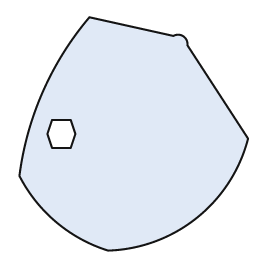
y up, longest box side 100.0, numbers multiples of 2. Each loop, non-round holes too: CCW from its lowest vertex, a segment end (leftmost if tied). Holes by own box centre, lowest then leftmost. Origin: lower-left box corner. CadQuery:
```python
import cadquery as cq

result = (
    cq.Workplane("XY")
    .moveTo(38.0, 0.0)
    .threePointArc((76.0, 14.0), (98.0, 48.0))
    .lineTo(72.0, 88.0)
    .threePointArc((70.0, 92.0), (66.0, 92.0))
    .lineTo(30.0, 100.0)
    .threePointArc((10.0, 68.0), (0.0, 32.0))
    .threePointArc((16.0, 12.0), (38.0, 0.0))
    .close()
    .moveTo(14.0, 44.0)
    .lineTo(22.0, 44.0)
    .lineTo(24.0, 50.0)
    .lineTo(22.0, 56.0)
    .lineTo(14.0, 56.0)
    .lineTo(12.0, 50.0)
    .close()
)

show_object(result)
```